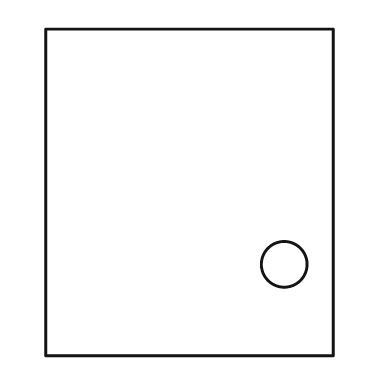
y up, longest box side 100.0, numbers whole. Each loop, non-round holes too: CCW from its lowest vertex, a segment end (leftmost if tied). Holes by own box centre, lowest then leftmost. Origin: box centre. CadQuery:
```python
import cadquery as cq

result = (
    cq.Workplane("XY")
    .moveTo(-44.0, -50.0)
    .lineTo(44.0, -50.0)
    .lineTo(44.0, 50.0)
    .lineTo(-44.0, 50.0)
    .close()
    .moveTo(29.0, -22.0)
    .circle(7.0)
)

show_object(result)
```